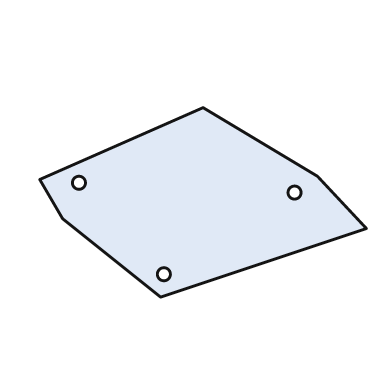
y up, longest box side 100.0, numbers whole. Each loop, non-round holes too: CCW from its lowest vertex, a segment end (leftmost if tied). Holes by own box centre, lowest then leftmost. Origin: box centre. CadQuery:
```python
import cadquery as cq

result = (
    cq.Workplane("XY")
    .moveTo(-13.0, -29.0)
    .lineTo(50.0, -8.0)
    .lineTo(35.0, 8.0)
    .lineTo(0.0, 29.0)
    .lineTo(-50.0, 7.0)
    .lineTo(-43.0, -5.0)
    .close()
    .moveTo(-12.0, -22.0)
    .circle(2.0)
    .moveTo(28.0, 3.0)
    .circle(2.0)
    .moveTo(-38.0, 6.0)
    .circle(2.0)
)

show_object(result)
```